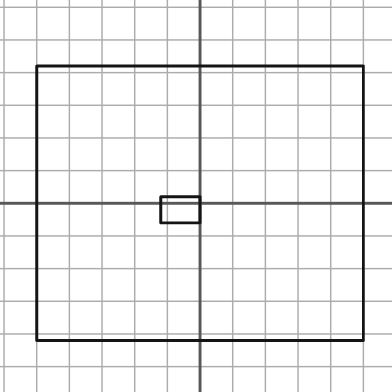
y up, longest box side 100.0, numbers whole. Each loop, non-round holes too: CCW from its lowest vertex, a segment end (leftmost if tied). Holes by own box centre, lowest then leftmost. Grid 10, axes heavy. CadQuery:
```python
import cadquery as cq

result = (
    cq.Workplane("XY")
    .moveTo(-50.0, -42.0)
    .lineTo(50.0, -42.0)
    .lineTo(50.0, 42.0)
    .lineTo(-50.0, 42.0)
    .close()
    .moveTo(-12.0, -6.0)
    .lineTo(0.0, -6.0)
    .lineTo(0.0, 2.0)
    .lineTo(-12.0, 2.0)
    .close()
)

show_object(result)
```